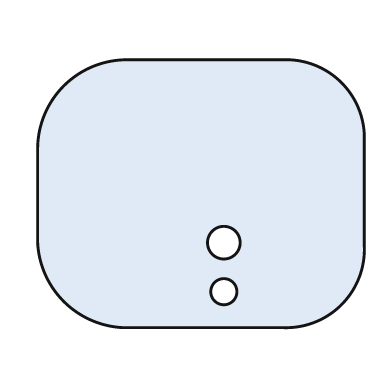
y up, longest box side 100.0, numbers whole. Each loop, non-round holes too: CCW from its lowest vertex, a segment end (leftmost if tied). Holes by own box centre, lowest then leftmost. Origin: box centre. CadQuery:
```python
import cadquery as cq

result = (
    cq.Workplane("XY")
    .moveTo(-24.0, -41.0)
    .lineTo(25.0, -41.0)
    .threePointArc((43.0, -34.0), (50.0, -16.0))
    .lineTo(50.0, 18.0)
    .threePointArc((43.0, 34.0), (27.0, 41.0))
    .lineTo(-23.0, 41.0)
    .threePointArc((-42.0, 33.0), (-50.0, 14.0))
    .lineTo(-50.0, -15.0)
    .threePointArc((-42.0, -33.0), (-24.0, -41.0))
    .close()
    .moveTo(7.0, -30.0)
    .circle(4.0)
    .moveTo(7.0, -15.0)
    .circle(5.0)
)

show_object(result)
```